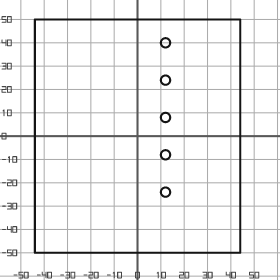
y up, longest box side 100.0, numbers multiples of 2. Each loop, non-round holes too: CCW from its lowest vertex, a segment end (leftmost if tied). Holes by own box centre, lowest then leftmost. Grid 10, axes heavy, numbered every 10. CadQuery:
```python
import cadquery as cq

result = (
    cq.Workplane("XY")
    .moveTo(-44.0, -50.0)
    .lineTo(44.0, -50.0)
    .lineTo(44.0, 50.0)
    .lineTo(-44.0, 50.0)
    .close()
    .moveTo(12.0, -24.0)
    .circle(2.0)
    .moveTo(12.0, -8.0)
    .circle(2.0)
    .moveTo(12.0, 8.0)
    .circle(2.0)
    .moveTo(12.0, 24.0)
    .circle(2.0)
    .moveTo(12.0, 40.0)
    .circle(2.0)
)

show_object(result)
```